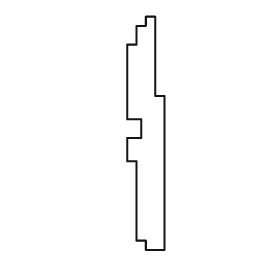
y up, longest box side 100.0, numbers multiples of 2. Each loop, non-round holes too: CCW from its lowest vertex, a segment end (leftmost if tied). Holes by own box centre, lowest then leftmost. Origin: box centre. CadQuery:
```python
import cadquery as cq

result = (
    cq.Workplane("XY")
    .moveTo(0.0, -50.0)
    .lineTo(8.0, -50.0)
    .lineTo(8.0, 16.0)
    .lineTo(4.0, 16.0)
    .lineTo(4.0, 50.0)
    .lineTo(0.0, 50.0)
    .lineTo(0.0, 46.0)
    .lineTo(-4.0, 46.0)
    .lineTo(-4.0, 38.0)
    .lineTo(-8.0, 38.0)
    .lineTo(-8.0, 6.0)
    .lineTo(-2.0, 6.0)
    .lineTo(-2.0, -2.0)
    .lineTo(-8.0, -2.0)
    .lineTo(-8.0, -12.0)
    .lineTo(-4.0, -12.0)
    .lineTo(-4.0, -46.0)
    .lineTo(0.0, -46.0)
    .close()
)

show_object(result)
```